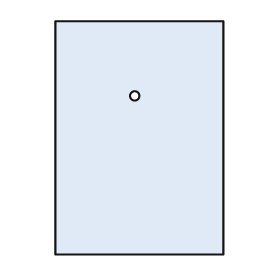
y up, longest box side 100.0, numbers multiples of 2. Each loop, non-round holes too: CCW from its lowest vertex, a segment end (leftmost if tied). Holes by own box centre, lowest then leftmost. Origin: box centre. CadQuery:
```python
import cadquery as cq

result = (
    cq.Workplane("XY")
    .moveTo(-36.0, -50.0)
    .lineTo(36.0, -50.0)
    .lineTo(36.0, 50.0)
    .lineTo(-36.0, 50.0)
    .close()
    .moveTo(-2.0, 18.0)
    .circle(2.0)
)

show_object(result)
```